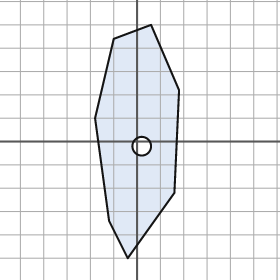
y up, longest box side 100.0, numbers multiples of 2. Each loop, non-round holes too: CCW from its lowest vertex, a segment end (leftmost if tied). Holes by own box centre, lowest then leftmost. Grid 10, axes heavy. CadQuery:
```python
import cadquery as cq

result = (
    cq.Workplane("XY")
    .moveTo(-4.0, -50.0)
    .lineTo(16.0, -22.0)
    .lineTo(18.0, 22.0)
    .lineTo(6.0, 50.0)
    .lineTo(-10.0, 44.0)
    .lineTo(-18.0, 10.0)
    .lineTo(-12.0, -34.0)
    .close()
    .moveTo(2.0, -2.0)
    .circle(4.0)
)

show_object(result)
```